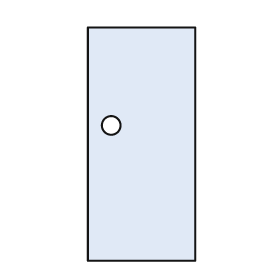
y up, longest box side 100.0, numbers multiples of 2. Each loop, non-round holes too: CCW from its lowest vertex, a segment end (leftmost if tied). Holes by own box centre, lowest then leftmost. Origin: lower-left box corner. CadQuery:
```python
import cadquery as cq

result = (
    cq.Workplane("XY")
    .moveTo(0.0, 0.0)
    .lineTo(46.0, 0.0)
    .lineTo(46.0, 100.0)
    .lineTo(0.0, 100.0)
    .close()
    .moveTo(10.0, 58.0)
    .circle(4.0)
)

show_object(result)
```